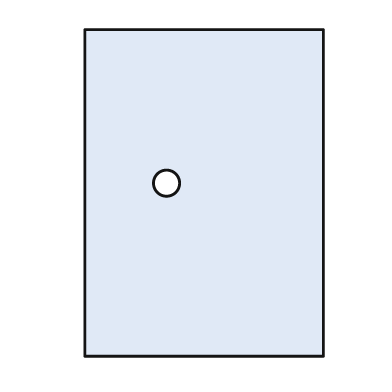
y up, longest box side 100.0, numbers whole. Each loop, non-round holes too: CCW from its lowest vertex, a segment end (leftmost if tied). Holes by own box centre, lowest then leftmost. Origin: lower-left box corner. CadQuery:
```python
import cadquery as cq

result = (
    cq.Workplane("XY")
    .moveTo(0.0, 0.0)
    .lineTo(73.0, 0.0)
    .lineTo(73.0, 100.0)
    .lineTo(0.0, 100.0)
    .close()
    .moveTo(25.0, 53.0)
    .circle(4.0)
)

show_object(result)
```